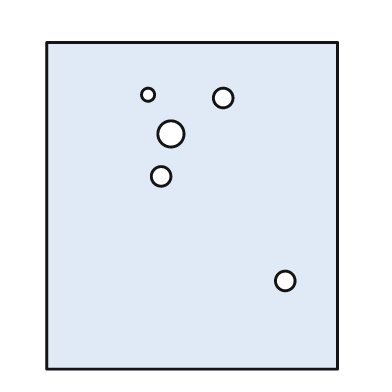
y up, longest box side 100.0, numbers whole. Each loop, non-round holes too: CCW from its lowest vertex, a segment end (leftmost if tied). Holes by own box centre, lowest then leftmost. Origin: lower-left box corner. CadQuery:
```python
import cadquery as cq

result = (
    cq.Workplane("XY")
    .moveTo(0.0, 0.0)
    .lineTo(89.0, 0.0)
    .lineTo(89.0, 100.0)
    .lineTo(0.0, 100.0)
    .close()
    .moveTo(73.0, 27.0)
    .circle(3.0)
    .moveTo(35.0, 59.0)
    .circle(3.0)
    .moveTo(38.0, 72.0)
    .circle(4.0)
    .moveTo(54.0, 83.0)
    .circle(3.0)
    .moveTo(31.0, 84.0)
    .circle(2.0)
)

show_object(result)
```